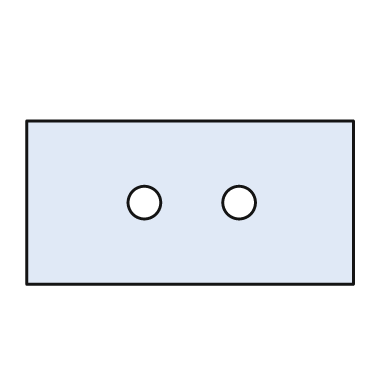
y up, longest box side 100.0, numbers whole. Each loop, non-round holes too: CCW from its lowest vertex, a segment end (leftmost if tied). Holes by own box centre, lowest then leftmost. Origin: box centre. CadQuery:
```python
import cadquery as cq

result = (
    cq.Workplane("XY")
    .moveTo(-50.0, -25.0)
    .lineTo(50.0, -25.0)
    .lineTo(50.0, 25.0)
    .lineTo(-50.0, 25.0)
    .close()
    .moveTo(-14.0, 0.0)
    .circle(5.0)
    .moveTo(15.0, 0.0)
    .circle(5.0)
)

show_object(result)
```